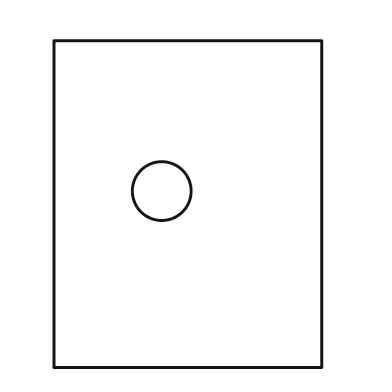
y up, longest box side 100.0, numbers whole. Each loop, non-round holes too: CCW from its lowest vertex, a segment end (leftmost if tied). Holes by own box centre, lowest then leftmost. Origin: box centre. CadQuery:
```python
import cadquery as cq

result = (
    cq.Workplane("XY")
    .moveTo(-41.0, -50.0)
    .lineTo(41.0, -50.0)
    .lineTo(41.0, 50.0)
    .lineTo(-41.0, 50.0)
    .close()
    .moveTo(-8.0, 4.0)
    .circle(9.0)
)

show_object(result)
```